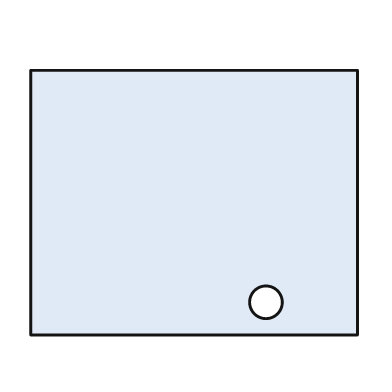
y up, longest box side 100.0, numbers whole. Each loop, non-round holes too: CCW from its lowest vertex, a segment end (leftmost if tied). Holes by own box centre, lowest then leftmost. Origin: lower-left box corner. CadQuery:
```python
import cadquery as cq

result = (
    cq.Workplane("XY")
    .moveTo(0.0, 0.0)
    .lineTo(100.0, 0.0)
    .lineTo(100.0, 81.0)
    .lineTo(0.0, 81.0)
    .close()
    .moveTo(72.0, 10.0)
    .circle(5.0)
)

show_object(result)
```